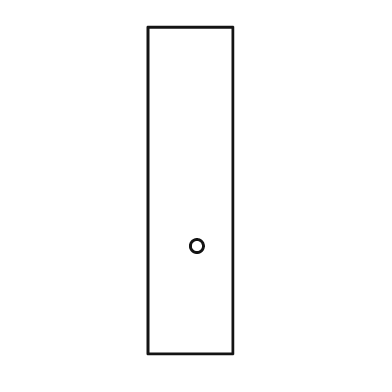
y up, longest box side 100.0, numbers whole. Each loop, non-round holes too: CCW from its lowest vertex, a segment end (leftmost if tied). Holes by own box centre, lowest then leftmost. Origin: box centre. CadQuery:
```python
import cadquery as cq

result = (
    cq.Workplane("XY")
    .moveTo(-13.0, -50.0)
    .lineTo(13.0, -50.0)
    .lineTo(13.0, 50.0)
    .lineTo(-13.0, 50.0)
    .close()
    .moveTo(2.0, -17.0)
    .circle(2.0)
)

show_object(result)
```